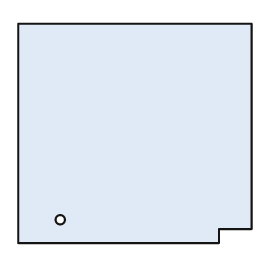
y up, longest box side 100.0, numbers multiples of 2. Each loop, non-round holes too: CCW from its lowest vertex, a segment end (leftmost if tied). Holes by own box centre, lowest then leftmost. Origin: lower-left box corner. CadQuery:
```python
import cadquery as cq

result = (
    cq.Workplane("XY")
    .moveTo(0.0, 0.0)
    .lineTo(86.0, 0.0)
    .lineTo(86.0, 6.0)
    .lineTo(100.0, 6.0)
    .lineTo(100.0, 94.0)
    .lineTo(0.0, 94.0)
    .close()
    .moveTo(18.0, 10.0)
    .circle(2.0)
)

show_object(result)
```